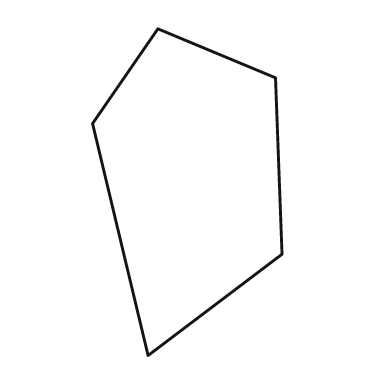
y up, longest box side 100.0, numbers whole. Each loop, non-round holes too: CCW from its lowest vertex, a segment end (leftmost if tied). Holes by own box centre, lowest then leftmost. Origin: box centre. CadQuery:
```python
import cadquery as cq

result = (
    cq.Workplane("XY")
    .moveTo(-12.0, -50.0)
    .lineTo(29.0, -19.0)
    .lineTo(27.0, 35.0)
    .lineTo(-9.0, 50.0)
    .lineTo(-29.0, 21.0)
    .close()
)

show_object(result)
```